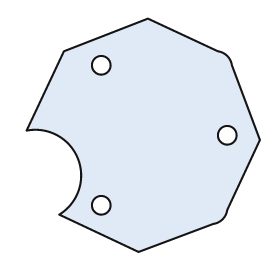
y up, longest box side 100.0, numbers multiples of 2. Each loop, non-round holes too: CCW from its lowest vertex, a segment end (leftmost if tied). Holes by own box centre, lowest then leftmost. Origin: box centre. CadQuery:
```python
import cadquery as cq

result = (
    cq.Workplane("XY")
    .moveTo(-2.0, -50.0)
    .lineTo(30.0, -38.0)
    .threePointArc((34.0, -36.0), (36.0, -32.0))
    .lineTo(50.0, -2.0)
    .lineTo(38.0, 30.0)
    .threePointArc((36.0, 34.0), (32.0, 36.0))
    .lineTo(2.0, 50.0)
    .lineTo(-34.0, 36.0)
    .lineTo(-50.0, 2.0)
    .threePointArc((-28.0, -10.0), (-36.0, -34.0))
    .close()
    .moveTo(-18.0, -30.0)
    .circle(4.0)
    .moveTo(36.0, 0.0)
    .circle(4.0)
    .moveTo(-18.0, 30.0)
    .circle(4.0)
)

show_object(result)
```